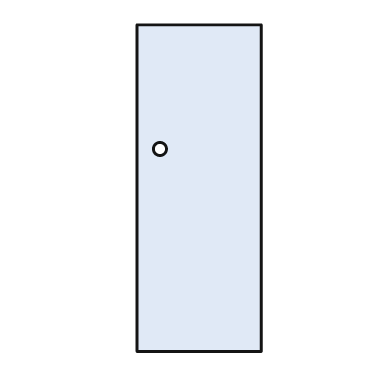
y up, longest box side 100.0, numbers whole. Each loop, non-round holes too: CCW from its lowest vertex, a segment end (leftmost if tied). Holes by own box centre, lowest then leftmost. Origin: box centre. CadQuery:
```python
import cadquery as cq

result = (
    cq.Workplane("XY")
    .moveTo(-19.0, -50.0)
    .lineTo(19.0, -50.0)
    .lineTo(19.0, 50.0)
    .lineTo(-19.0, 50.0)
    .close()
    .moveTo(-12.0, 12.0)
    .circle(2.0)
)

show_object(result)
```